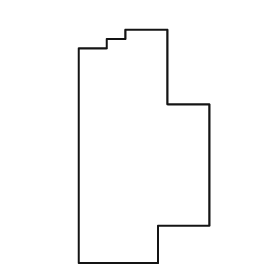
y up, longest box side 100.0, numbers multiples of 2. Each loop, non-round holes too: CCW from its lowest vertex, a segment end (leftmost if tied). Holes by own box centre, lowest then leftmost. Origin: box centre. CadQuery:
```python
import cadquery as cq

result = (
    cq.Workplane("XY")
    .moveTo(-28.0, -50.0)
    .lineTo(6.0, -50.0)
    .lineTo(6.0, -34.0)
    .lineTo(28.0, -34.0)
    .lineTo(28.0, 18.0)
    .lineTo(10.0, 18.0)
    .lineTo(10.0, 50.0)
    .lineTo(-8.0, 50.0)
    .lineTo(-8.0, 46.0)
    .lineTo(-16.0, 46.0)
    .lineTo(-16.0, 42.0)
    .lineTo(-28.0, 42.0)
    .close()
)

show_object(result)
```